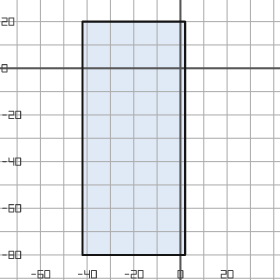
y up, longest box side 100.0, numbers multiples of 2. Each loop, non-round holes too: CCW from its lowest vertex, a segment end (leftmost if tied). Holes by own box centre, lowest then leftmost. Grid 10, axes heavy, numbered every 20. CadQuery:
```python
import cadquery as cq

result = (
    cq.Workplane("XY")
    .moveTo(-42.0, -80.0)
    .lineTo(2.0, -80.0)
    .lineTo(2.0, 20.0)
    .lineTo(-42.0, 20.0)
    .close()
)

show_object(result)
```